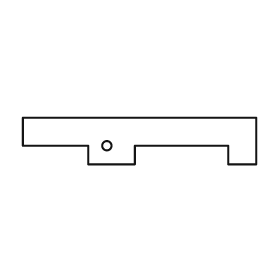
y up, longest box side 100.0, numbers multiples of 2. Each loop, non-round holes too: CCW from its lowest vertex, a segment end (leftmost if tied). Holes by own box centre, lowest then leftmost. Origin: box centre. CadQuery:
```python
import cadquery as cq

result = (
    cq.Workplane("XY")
    .moveTo(-22.0, -10.0)
    .lineTo(-2.0, -10.0)
    .lineTo(-2.0, -2.0)
    .lineTo(38.0, -2.0)
    .lineTo(38.0, -10.0)
    .lineTo(50.0, -10.0)
    .lineTo(50.0, 10.0)
    .lineTo(-50.0, 10.0)
    .lineTo(-50.0, -2.0)
    .lineTo(-22.0, -2.0)
    .close()
    .moveTo(-14.0, -2.0)
    .circle(2.0)
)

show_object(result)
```